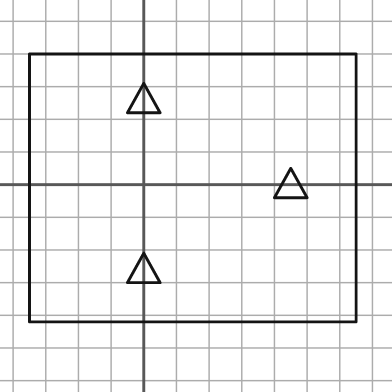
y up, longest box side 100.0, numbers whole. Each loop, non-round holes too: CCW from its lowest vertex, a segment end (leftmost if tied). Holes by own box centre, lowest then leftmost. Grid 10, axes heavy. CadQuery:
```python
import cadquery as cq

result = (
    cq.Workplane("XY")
    .moveTo(-35.0, -42.0)
    .lineTo(65.0, -42.0)
    .lineTo(65.0, 40.0)
    .lineTo(-35.0, 40.0)
    .close()
    .moveTo(-5.0, -30.0)
    .lineTo(5.0, -30.0)
    .lineTo(0.0, -21.0)
    .close()
    .moveTo(40.0, -4.0)
    .lineTo(50.0, -4.0)
    .lineTo(45.0, 5.0)
    .close()
    .moveTo(-5.0, 22.0)
    .lineTo(5.0, 22.0)
    .lineTo(0.0, 31.0)
    .close()
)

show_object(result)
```